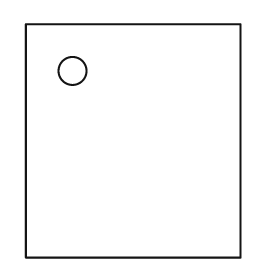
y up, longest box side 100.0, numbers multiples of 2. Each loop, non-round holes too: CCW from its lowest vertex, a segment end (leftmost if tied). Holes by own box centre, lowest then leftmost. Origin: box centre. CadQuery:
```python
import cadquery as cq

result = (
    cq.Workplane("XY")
    .moveTo(-46.0, -50.0)
    .lineTo(46.0, -50.0)
    .lineTo(46.0, 50.0)
    .lineTo(-46.0, 50.0)
    .close()
    .moveTo(-26.0, 30.0)
    .circle(6.0)
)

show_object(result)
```